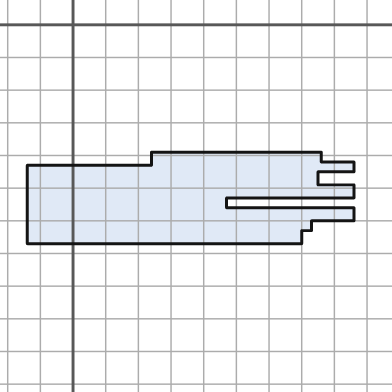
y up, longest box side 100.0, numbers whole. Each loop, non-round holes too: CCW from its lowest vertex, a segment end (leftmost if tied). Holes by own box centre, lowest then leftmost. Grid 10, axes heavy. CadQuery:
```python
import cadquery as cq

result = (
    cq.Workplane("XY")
    .moveTo(-14.0, -67.0)
    .lineTo(70.0, -67.0)
    .lineTo(70.0, -63.0)
    .lineTo(73.0, -63.0)
    .lineTo(73.0, -60.0)
    .lineTo(86.0, -60.0)
    .lineTo(86.0, -56.0)
    .lineTo(47.0, -56.0)
    .lineTo(47.0, -53.0)
    .lineTo(86.0, -53.0)
    .lineTo(86.0, -49.0)
    .lineTo(75.0, -49.0)
    .lineTo(75.0, -45.0)
    .lineTo(86.0, -45.0)
    .lineTo(86.0, -42.0)
    .lineTo(76.0, -42.0)
    .lineTo(76.0, -39.0)
    .lineTo(24.0, -39.0)
    .lineTo(24.0, -43.0)
    .lineTo(-14.0, -43.0)
    .close()
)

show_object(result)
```